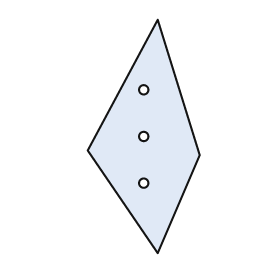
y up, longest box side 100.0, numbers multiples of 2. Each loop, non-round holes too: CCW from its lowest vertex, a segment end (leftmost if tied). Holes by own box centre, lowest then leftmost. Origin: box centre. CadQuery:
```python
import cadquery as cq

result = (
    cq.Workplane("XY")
    .moveTo(6.0, -50.0)
    .lineTo(24.0, -8.0)
    .lineTo(6.0, 50.0)
    .lineTo(-24.0, -6.0)
    .close()
    .moveTo(0.0, -20.0)
    .circle(2.0)
    .moveTo(0.0, 0.0)
    .circle(2.0)
    .moveTo(0.0, 20.0)
    .circle(2.0)
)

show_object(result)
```